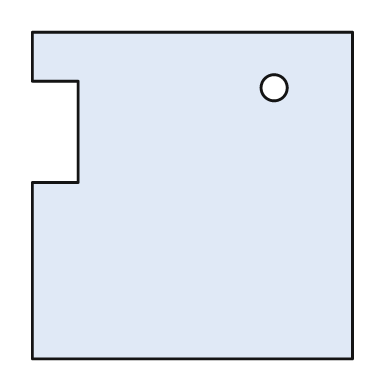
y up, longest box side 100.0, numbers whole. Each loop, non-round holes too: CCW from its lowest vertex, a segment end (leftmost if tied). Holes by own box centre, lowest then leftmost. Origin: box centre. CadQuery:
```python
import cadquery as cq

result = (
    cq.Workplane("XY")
    .moveTo(-49.0, -50.0)
    .lineTo(49.0, -50.0)
    .lineTo(49.0, 50.0)
    .lineTo(-49.0, 50.0)
    .lineTo(-49.0, 35.0)
    .lineTo(-35.0, 35.0)
    .lineTo(-35.0, 4.0)
    .lineTo(-49.0, 4.0)
    .close()
    .moveTo(25.0, 33.0)
    .circle(4.0)
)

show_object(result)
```